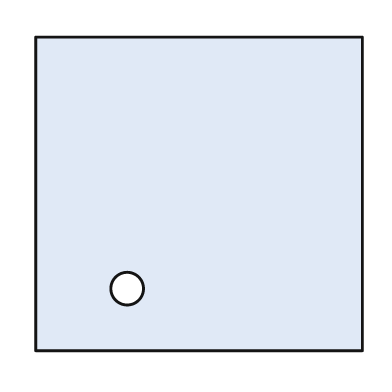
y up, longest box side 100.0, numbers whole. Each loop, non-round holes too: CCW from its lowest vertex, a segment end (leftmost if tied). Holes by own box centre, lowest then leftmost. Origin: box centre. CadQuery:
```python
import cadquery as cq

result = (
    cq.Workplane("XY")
    .moveTo(-50.0, -48.0)
    .lineTo(50.0, -48.0)
    .lineTo(50.0, 48.0)
    .lineTo(-50.0, 48.0)
    .close()
    .moveTo(-22.0, -29.0)
    .circle(5.0)
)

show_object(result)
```